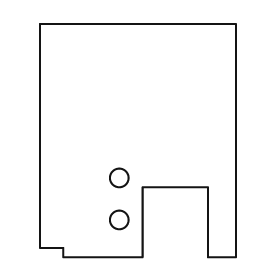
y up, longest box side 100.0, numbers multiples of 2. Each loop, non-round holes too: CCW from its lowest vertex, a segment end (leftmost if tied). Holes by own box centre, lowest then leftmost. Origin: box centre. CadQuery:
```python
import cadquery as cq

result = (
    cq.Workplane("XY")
    .moveTo(-32.0, -50.0)
    .lineTo(2.0, -50.0)
    .lineTo(2.0, -20.0)
    .lineTo(30.0, -20.0)
    .lineTo(30.0, -50.0)
    .lineTo(42.0, -50.0)
    .lineTo(42.0, 50.0)
    .lineTo(-42.0, 50.0)
    .lineTo(-42.0, -46.0)
    .lineTo(-32.0, -46.0)
    .close()
    .moveTo(-8.0, -34.0)
    .circle(4.0)
    .moveTo(-8.0, -16.0)
    .circle(4.0)
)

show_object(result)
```